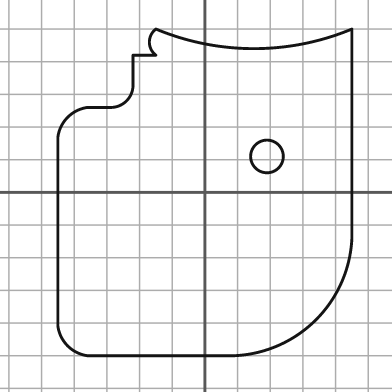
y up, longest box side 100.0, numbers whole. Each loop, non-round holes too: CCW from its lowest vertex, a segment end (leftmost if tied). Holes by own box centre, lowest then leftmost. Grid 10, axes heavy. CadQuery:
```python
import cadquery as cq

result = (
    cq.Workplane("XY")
    .moveTo(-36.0, -50.0)
    .lineTo(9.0, -50.0)
    .threePointArc((34.0, -39.0), (45.0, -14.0))
    .lineTo(45.0, 50.0)
    .threePointArc((15.0, 44.0), (-15.0, 50.0))
    .threePointArc((-17.0, 46.0), (-15.0, 42.0))
    .lineTo(-22.0, 42.0)
    .lineTo(-22.0, 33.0)
    .threePointArc((-24.0, 28.0), (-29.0, 26.0))
    .lineTo(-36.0, 26.0)
    .threePointArc((-42.0, 23.0), (-45.0, 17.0))
    .lineTo(-45.0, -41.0)
    .threePointArc((-42.0, -47.0), (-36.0, -50.0))
    .close()
    .moveTo(19.0, 11.0)
    .circle(5.0)
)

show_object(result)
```